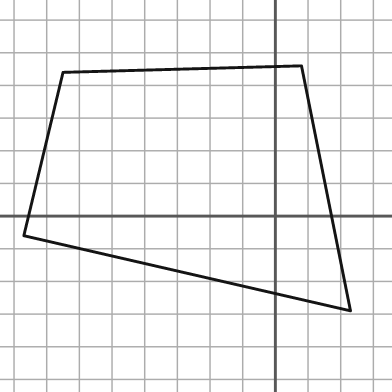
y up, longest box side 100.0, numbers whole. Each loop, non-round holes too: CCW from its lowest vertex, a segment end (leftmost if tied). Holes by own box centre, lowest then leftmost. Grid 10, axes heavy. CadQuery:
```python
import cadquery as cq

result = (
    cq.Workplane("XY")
    .moveTo(23.0, -29.0)
    .lineTo(8.0, 46.0)
    .lineTo(-65.0, 44.0)
    .lineTo(-77.0, -6.0)
    .close()
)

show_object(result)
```